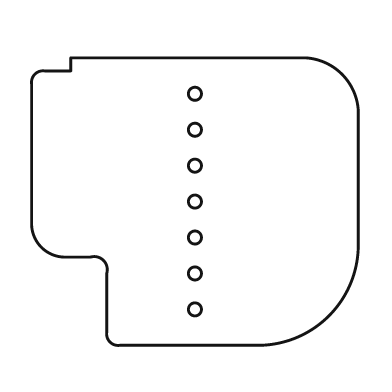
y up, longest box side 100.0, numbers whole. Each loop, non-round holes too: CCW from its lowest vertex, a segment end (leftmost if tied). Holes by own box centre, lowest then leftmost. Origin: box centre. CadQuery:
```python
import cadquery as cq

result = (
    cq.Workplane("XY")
    .moveTo(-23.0, -44.0)
    .lineTo(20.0, -44.0)
    .threePointArc((41.0, -35.0), (50.0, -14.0))
    .lineTo(50.0, 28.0)
    .threePointArc((45.0, 39.0), (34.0, 44.0))
    .lineTo(-38.0, 44.0)
    .lineTo(-38.0, 40.0)
    .lineTo(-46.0, 40.0)
    .threePointArc((-49.0, 39.0), (-50.0, 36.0))
    .lineTo(-50.0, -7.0)
    .threePointArc((-47.0, -14.0), (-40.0, -17.0))
    .lineTo(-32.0, -17.0)
    .threePointArc((-28.0, -18.0), (-27.0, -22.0))
    .lineTo(-27.0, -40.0)
    .threePointArc((-26.0, -43.0), (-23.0, -44.0))
    .close()
    .moveTo(0.0, -33.0)
    .circle(2.0)
    .moveTo(0.0, -22.0)
    .circle(2.0)
    .moveTo(0.0, -11.0)
    .circle(2.0)
    .moveTo(0.0, 0.0)
    .circle(2.0)
    .moveTo(0.0, 11.0)
    .circle(2.0)
    .moveTo(0.0, 22.0)
    .circle(2.0)
    .moveTo(0.0, 33.0)
    .circle(2.0)
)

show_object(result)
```